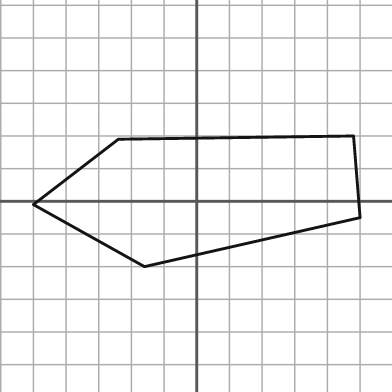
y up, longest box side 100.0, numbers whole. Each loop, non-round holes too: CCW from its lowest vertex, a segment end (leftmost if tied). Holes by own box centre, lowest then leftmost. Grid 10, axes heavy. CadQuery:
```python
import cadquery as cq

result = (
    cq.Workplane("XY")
    .moveTo(-16.0, -20.0)
    .lineTo(50.0, -5.0)
    .lineTo(48.0, 20.0)
    .lineTo(-24.0, 19.0)
    .lineTo(-50.0, -1.0)
    .close()
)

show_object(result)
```